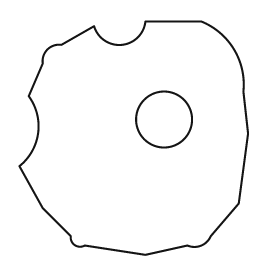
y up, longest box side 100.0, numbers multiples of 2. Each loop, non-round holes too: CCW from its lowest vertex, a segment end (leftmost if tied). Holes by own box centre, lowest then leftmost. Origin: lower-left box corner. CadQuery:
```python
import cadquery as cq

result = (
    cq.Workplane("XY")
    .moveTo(54.0, 0.0)
    .lineTo(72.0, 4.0)
    .threePointArc((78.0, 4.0), (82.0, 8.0))
    .lineTo(94.0, 22.0)
    .lineTo(98.0, 52.0)
    .lineTo(96.0, 70.0)
    .threePointArc((92.0, 88.0), (78.0, 100.0))
    .lineTo(54.0, 100.0)
    .threePointArc((44.0, 90.0), (32.0, 98.0))
    .lineTo(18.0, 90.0)
    .threePointArc((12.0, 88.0), (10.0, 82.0))
    .lineTo(4.0, 68.0)
    .threePointArc((8.0, 52.0), (0.0, 38.0))
    .lineTo(10.0, 20.0)
    .lineTo(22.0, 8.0)
    .threePointArc((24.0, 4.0), (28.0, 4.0))
    .close()
    .moveTo(62.0, 58.0)
    .circle(12.0)
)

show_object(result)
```